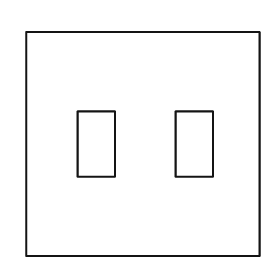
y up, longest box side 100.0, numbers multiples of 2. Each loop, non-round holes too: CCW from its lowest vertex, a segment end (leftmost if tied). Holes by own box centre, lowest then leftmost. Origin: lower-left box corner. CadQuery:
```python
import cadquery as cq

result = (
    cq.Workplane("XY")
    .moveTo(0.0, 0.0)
    .lineTo(100.0, 0.0)
    .lineTo(100.0, 96.0)
    .lineTo(0.0, 96.0)
    .close()
    .moveTo(22.0, 34.0)
    .lineTo(38.0, 34.0)
    .lineTo(38.0, 62.0)
    .lineTo(22.0, 62.0)
    .close()
    .moveTo(64.0, 34.0)
    .lineTo(80.0, 34.0)
    .lineTo(80.0, 62.0)
    .lineTo(64.0, 62.0)
    .close()
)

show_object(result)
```